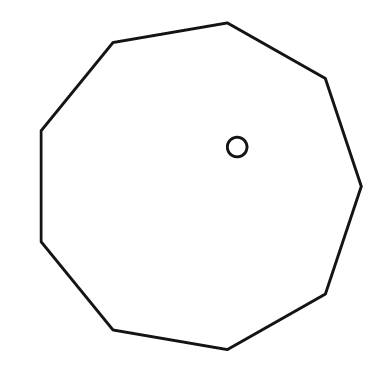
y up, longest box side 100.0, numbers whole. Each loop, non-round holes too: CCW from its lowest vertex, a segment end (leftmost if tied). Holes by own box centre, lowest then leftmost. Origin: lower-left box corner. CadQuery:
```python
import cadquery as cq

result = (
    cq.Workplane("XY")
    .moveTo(57.0, 0.0)
    .lineTo(87.0, 17.0)
    .lineTo(98.0, 50.0)
    .lineTo(87.0, 83.0)
    .lineTo(57.0, 100.0)
    .lineTo(22.0, 94.0)
    .lineTo(0.0, 67.0)
    .lineTo(0.0, 33.0)
    .lineTo(22.0, 6.0)
    .close()
    .moveTo(60.0, 62.0)
    .circle(3.0)
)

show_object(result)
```